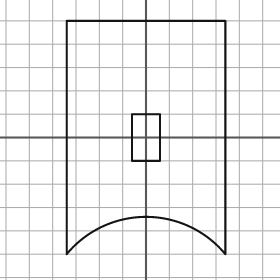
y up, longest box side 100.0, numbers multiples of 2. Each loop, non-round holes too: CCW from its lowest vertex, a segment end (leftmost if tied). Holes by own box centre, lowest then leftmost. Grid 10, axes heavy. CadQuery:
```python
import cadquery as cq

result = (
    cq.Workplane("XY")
    .moveTo(-34.0, -50.0)
    .threePointArc((0.0, -34.0), (34.0, -50.0))
    .lineTo(34.0, 50.0)
    .lineTo(-34.0, 50.0)
    .close()
    .moveTo(-6.0, -10.0)
    .lineTo(6.0, -10.0)
    .lineTo(6.0, 10.0)
    .lineTo(-6.0, 10.0)
    .close()
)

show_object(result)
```